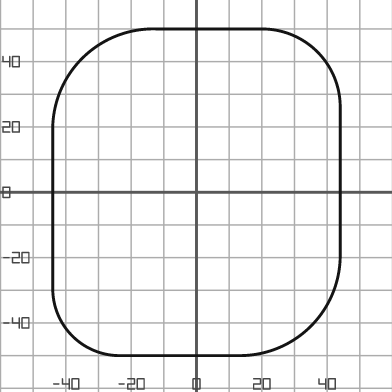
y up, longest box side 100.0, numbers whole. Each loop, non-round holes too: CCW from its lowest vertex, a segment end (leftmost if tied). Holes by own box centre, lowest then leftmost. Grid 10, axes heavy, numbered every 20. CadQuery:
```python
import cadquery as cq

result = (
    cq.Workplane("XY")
    .moveTo(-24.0, -50.0)
    .lineTo(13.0, -50.0)
    .threePointArc((35.0, -41.0), (44.0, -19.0))
    .lineTo(44.0, 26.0)
    .threePointArc((37.0, 43.0), (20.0, 50.0))
    .lineTo(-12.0, 50.0)
    .threePointArc((-35.0, 41.0), (-44.0, 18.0))
    .lineTo(-44.0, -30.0)
    .threePointArc((-38.0, -44.0), (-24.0, -50.0))
    .close()
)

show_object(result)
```